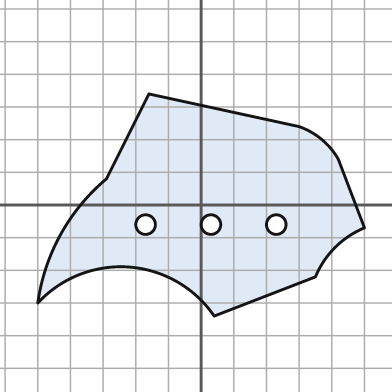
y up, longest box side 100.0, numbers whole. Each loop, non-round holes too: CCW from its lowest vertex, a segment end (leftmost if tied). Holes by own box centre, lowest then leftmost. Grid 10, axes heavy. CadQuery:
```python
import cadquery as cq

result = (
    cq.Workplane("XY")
    .moveTo(4.0, -34.0)
    .lineTo(35.0, -22.0)
    .threePointArc((41.0, -13.0), (50.0, -7.0))
    .lineTo(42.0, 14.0)
    .threePointArc((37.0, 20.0), (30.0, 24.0))
    .lineTo(-16.0, 34.0)
    .lineTo(-29.0, 8.0)
    .threePointArc((-43.0, -9.0), (-50.0, -30.0))
    .threePointArc((-22.0, -19.0), (4.0, -34.0))
    .close()
    .moveTo(-17.0, -6.0)
    .circle(3.0)
    .moveTo(3.0, -6.0)
    .circle(3.0)
    .moveTo(23.0, -6.0)
    .circle(3.0)
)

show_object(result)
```